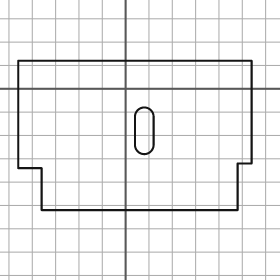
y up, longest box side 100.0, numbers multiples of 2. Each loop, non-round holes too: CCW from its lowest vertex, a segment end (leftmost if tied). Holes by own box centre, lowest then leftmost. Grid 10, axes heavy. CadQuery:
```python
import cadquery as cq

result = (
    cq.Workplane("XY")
    .moveTo(-36.0, -52.0)
    .lineTo(48.0, -52.0)
    .lineTo(48.0, -32.0)
    .lineTo(54.0, -32.0)
    .lineTo(54.0, 12.0)
    .lineTo(-46.0, 12.0)
    .lineTo(-46.0, -34.0)
    .lineTo(-36.0, -34.0)
    .close()
    .moveTo(4.0, -24.0)
    .threePointArc((8.0, -28.0), (12.0, -24.0))
    .lineTo(12.0, -12.0)
    .threePointArc((8.0, -8.0), (4.0, -12.0))
    .close()
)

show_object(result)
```